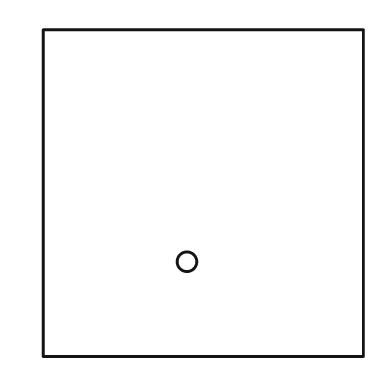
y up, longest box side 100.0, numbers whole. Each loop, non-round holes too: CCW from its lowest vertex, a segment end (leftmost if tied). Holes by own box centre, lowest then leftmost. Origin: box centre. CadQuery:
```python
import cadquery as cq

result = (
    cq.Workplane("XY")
    .moveTo(-49.0, -50.0)
    .lineTo(49.0, -50.0)
    .lineTo(49.0, 50.0)
    .lineTo(-49.0, 50.0)
    .close()
    .moveTo(-5.0, -21.0)
    .circle(3.0)
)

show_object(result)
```